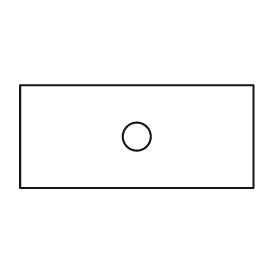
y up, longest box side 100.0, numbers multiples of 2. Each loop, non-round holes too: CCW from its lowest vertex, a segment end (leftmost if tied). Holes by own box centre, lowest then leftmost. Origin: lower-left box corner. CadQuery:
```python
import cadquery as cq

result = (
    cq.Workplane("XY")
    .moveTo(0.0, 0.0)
    .lineTo(100.0, 0.0)
    .lineTo(100.0, 44.0)
    .lineTo(0.0, 44.0)
    .close()
    .moveTo(50.0, 22.0)
    .circle(6.0)
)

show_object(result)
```